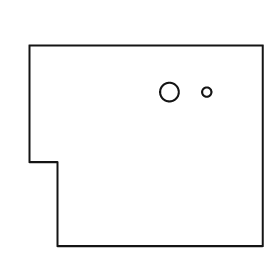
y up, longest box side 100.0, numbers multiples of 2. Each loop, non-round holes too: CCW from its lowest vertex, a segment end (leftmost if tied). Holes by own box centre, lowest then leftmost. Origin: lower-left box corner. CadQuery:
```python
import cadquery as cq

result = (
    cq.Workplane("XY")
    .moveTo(12.0, 0.0)
    .lineTo(100.0, 0.0)
    .lineTo(100.0, 86.0)
    .lineTo(0.0, 86.0)
    .lineTo(0.0, 36.0)
    .lineTo(12.0, 36.0)
    .close()
    .moveTo(60.0, 66.0)
    .circle(4.0)
    .moveTo(76.0, 66.0)
    .circle(2.0)
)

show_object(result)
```